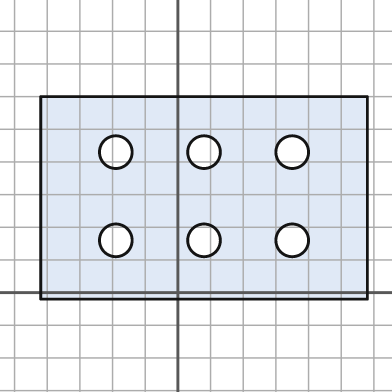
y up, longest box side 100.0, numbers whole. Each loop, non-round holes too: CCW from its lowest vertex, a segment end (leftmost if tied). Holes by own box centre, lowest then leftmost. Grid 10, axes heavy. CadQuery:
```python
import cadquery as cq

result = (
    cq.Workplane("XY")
    .moveTo(-42.0, -2.0)
    .lineTo(58.0, -2.0)
    .lineTo(58.0, 60.0)
    .lineTo(-42.0, 60.0)
    .close()
    .moveTo(-19.0, 16.0)
    .circle(5.0)
    .moveTo(8.0, 16.0)
    .circle(5.0)
    .moveTo(35.0, 16.0)
    .circle(5.0)
    .moveTo(-19.0, 43.0)
    .circle(5.0)
    .moveTo(8.0, 43.0)
    .circle(5.0)
    .moveTo(35.0, 43.0)
    .circle(5.0)
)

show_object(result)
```